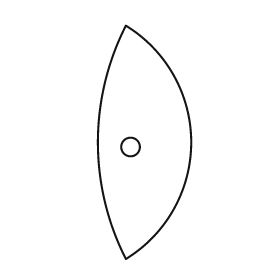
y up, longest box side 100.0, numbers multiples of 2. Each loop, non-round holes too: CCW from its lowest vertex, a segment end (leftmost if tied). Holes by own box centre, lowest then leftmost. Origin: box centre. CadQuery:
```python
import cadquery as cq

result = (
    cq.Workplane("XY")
    .moveTo(-8.0, -50.0)
    .threePointArc((20.0, 0.0), (-8.0, 50.0))
    .threePointArc((-20.0, 0.0), (-8.0, -50.0))
    .close()
    .moveTo(-6.0, -2.0)
    .circle(4.0)
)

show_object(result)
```